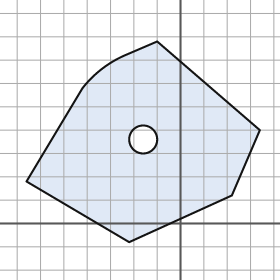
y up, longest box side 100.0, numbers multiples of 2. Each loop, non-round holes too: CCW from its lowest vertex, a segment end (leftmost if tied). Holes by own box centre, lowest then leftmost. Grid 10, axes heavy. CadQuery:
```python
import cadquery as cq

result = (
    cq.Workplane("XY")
    .moveTo(-22.0, -8.0)
    .lineTo(22.0, 12.0)
    .lineTo(34.0, 40.0)
    .lineTo(-10.0, 78.0)
    .lineTo(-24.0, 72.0)
    .threePointArc((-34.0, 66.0), (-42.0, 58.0))
    .lineTo(-66.0, 18.0)
    .close()
    .moveTo(-16.0, 36.0)
    .circle(6.0)
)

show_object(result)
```